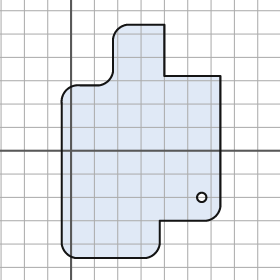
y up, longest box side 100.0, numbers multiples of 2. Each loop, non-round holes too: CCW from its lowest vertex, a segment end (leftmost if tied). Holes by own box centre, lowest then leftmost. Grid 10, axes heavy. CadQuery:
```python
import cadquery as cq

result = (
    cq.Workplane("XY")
    .moveTo(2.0, -46.0)
    .lineTo(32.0, -46.0)
    .threePointArc((36.0, -44.0), (38.0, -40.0))
    .lineTo(38.0, -30.0)
    .lineTo(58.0, -30.0)
    .threePointArc((62.0, -28.0), (64.0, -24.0))
    .lineTo(64.0, 32.0)
    .lineTo(40.0, 32.0)
    .lineTo(40.0, 54.0)
    .lineTo(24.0, 54.0)
    .threePointArc((20.0, 52.0), (18.0, 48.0))
    .lineTo(18.0, 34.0)
    .threePointArc((16.0, 30.0), (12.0, 28.0))
    .lineTo(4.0, 28.0)
    .threePointArc((-2.0, 26.0), (-4.0, 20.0))
    .lineTo(-4.0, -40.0)
    .threePointArc((-2.0, -44.0), (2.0, -46.0))
    .close()
    .moveTo(56.0, -20.0)
    .circle(2.0)
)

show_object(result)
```